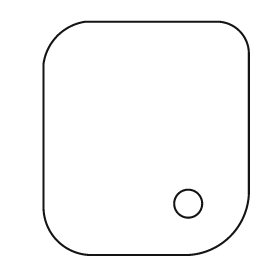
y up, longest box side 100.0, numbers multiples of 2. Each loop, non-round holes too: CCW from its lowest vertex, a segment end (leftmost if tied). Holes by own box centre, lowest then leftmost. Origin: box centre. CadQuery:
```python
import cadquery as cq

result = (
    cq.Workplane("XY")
    .moveTo(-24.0, -50.0)
    .lineTo(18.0, -50.0)
    .threePointArc((36.0, -42.0), (44.0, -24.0))
    .lineTo(44.0, 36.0)
    .threePointArc((40.0, 46.0), (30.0, 50.0))
    .lineTo(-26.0, 50.0)
    .threePointArc((-38.0, 44.0), (-44.0, 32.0))
    .lineTo(-44.0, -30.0)
    .threePointArc((-38.0, -44.0), (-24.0, -50.0))
    .close()
    .moveTo(18.0, -28.0)
    .circle(6.0)
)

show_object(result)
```